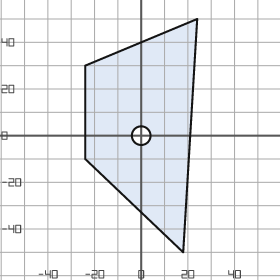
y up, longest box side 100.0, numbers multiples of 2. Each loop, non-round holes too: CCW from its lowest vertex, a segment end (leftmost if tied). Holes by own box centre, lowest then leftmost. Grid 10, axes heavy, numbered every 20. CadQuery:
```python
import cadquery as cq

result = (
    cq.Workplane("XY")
    .moveTo(18.0, -50.0)
    .lineTo(24.0, 50.0)
    .lineTo(-24.0, 30.0)
    .lineTo(-24.0, -10.0)
    .close()
    .moveTo(0.0, 0.0)
    .circle(4.0)
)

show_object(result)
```